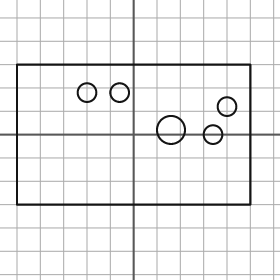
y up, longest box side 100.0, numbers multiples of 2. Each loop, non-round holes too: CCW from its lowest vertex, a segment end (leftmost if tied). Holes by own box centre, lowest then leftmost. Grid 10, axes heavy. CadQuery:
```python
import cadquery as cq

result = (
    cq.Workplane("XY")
    .moveTo(-50.0, -30.0)
    .lineTo(50.0, -30.0)
    .lineTo(50.0, 30.0)
    .lineTo(-50.0, 30.0)
    .close()
    .moveTo(34.0, 0.0)
    .circle(4.0)
    .moveTo(16.0, 2.0)
    .circle(6.0)
    .moveTo(40.0, 12.0)
    .circle(4.0)
    .moveTo(-20.0, 18.0)
    .circle(4.0)
    .moveTo(-6.0, 18.0)
    .circle(4.0)
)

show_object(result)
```